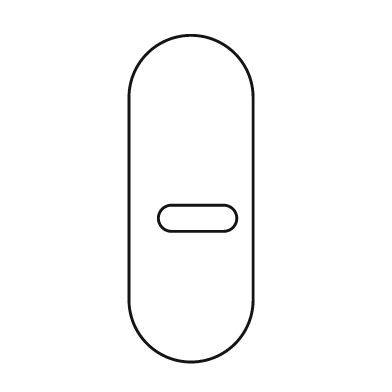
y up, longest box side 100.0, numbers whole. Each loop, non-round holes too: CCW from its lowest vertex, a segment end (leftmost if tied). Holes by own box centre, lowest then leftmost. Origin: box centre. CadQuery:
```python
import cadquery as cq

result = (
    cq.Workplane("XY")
    .moveTo(-19.0, -31.0)
    .threePointArc((0.0, -50.0), (19.0, -31.0))
    .lineTo(19.0, 31.0)
    .threePointArc((0.0, 50.0), (-19.0, 31.0))
    .close()
    .moveTo(-6.0, -10.0)
    .lineTo(10.0, -10.0)
    .threePointArc((14.0, -6.0), (10.0, -2.0))
    .lineTo(-6.0, -2.0)
    .threePointArc((-10.0, -6.0), (-6.0, -10.0))
    .close()
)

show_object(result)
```